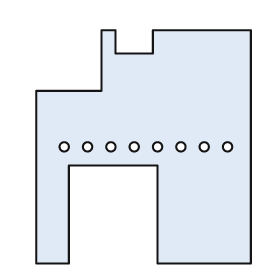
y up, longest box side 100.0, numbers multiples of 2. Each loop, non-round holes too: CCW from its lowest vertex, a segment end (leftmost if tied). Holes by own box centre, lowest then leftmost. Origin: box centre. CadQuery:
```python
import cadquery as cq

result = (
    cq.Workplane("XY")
    .moveTo(-46.0, -50.0)
    .lineTo(-32.0, -50.0)
    .lineTo(-32.0, -8.0)
    .lineTo(6.0, -8.0)
    .lineTo(6.0, -50.0)
    .lineTo(46.0, -50.0)
    .lineTo(46.0, 50.0)
    .lineTo(4.0, 50.0)
    .lineTo(4.0, 40.0)
    .lineTo(-12.0, 40.0)
    .lineTo(-12.0, 50.0)
    .lineTo(-18.0, 50.0)
    .lineTo(-18.0, 24.0)
    .lineTo(-46.0, 24.0)
    .close()
    .moveTo(-34.0, 0.0)
    .circle(2.0)
    .moveTo(-24.0, 0.0)
    .circle(2.0)
    .moveTo(-14.0, 0.0)
    .circle(2.0)
    .moveTo(-4.0, 0.0)
    .circle(2.0)
    .moveTo(6.0, 0.0)
    .circle(2.0)
    .moveTo(16.0, 0.0)
    .circle(2.0)
    .moveTo(26.0, 0.0)
    .circle(2.0)
    .moveTo(36.0, 0.0)
    .circle(2.0)
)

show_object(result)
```